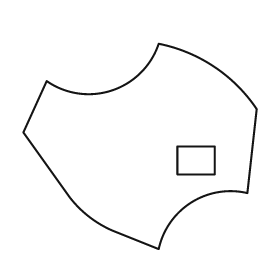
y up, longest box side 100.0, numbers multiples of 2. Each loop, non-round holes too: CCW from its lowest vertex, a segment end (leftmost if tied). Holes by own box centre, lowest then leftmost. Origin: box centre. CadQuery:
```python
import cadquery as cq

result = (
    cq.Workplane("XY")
    .moveTo(8.0, -44.0)
    .threePointArc((22.0, -24.0), (46.0, -20.0))
    .lineTo(50.0, 16.0)
    .threePointArc((32.0, 34.0), (8.0, 44.0))
    .threePointArc((-12.0, 24.0), (-40.0, 28.0))
    .lineTo(-50.0, 6.0)
    .lineTo(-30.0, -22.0)
    .threePointArc((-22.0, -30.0), (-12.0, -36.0))
    .close()
    .moveTo(16.0, -12.0)
    .lineTo(32.0, -12.0)
    .lineTo(32.0, 0.0)
    .lineTo(16.0, 0.0)
    .close()
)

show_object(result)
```